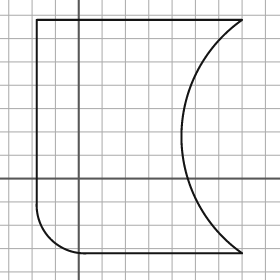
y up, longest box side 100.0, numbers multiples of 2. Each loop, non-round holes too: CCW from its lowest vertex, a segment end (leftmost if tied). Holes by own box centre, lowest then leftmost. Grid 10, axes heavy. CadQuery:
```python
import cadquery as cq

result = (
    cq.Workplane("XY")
    .moveTo(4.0, -32.0)
    .lineTo(70.0, -32.0)
    .threePointArc((44.0, 18.0), (70.0, 68.0))
    .lineTo(-18.0, 68.0)
    .lineTo(-18.0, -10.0)
    .threePointArc((-12.0, -26.0), (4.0, -32.0))
    .close()
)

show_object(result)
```